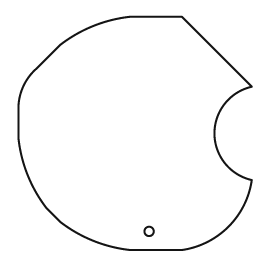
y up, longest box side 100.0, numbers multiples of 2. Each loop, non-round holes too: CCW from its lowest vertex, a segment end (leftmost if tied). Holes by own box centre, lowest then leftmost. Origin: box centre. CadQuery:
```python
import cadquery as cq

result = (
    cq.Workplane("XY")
    .moveTo(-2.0, -50.0)
    .lineTo(20.0, -50.0)
    .threePointArc((40.0, -40.0), (50.0, -20.0))
    .threePointArc((34.0, 0.0), (50.0, 20.0))
    .lineTo(20.0, 50.0)
    .lineTo(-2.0, 50.0)
    .threePointArc((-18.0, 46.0), (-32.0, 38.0))
    .lineTo(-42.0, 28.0)
    .threePointArc((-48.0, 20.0), (-50.0, 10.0))
    .lineTo(-50.0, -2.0)
    .threePointArc((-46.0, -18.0), (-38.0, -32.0))
    .lineTo(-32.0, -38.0)
    .threePointArc((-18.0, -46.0), (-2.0, -50.0))
    .close()
    .moveTo(6.0, -42.0)
    .circle(2.0)
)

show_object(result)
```